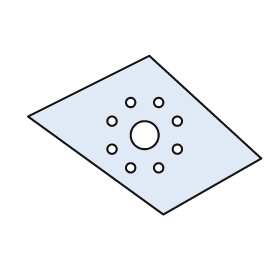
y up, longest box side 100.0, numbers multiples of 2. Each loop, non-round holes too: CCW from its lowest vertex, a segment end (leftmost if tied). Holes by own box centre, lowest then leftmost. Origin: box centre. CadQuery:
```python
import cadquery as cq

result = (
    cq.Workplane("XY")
    .moveTo(8.0, -34.0)
    .lineTo(50.0, -10.0)
    .lineTo(2.0, 34.0)
    .lineTo(-50.0, 8.0)
    .close()
    .moveTo(-6.0, -14.0)
    .circle(2.0)
    .moveTo(6.0, -14.0)
    .circle(2.0)
    .moveTo(-14.0, -6.0)
    .circle(2.0)
    .moveTo(14.0, -6.0)
    .circle(2.0)
    .moveTo(0.0, 0.0)
    .circle(6.0)
    .moveTo(-14.0, 6.0)
    .circle(2.0)
    .moveTo(14.0, 6.0)
    .circle(2.0)
    .moveTo(-6.0, 14.0)
    .circle(2.0)
    .moveTo(6.0, 14.0)
    .circle(2.0)
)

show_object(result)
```